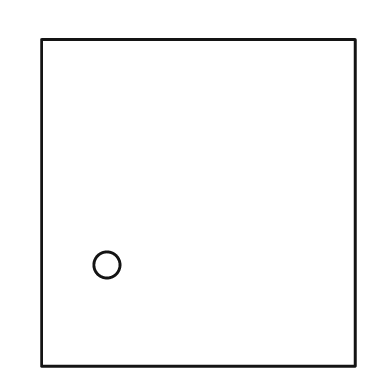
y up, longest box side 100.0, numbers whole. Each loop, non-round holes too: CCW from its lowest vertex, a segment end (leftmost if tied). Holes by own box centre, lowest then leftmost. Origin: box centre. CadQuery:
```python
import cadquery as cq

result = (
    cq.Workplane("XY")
    .moveTo(-48.0, -50.0)
    .lineTo(48.0, -50.0)
    .lineTo(48.0, 50.0)
    .lineTo(-48.0, 50.0)
    .close()
    .moveTo(-28.0, -19.0)
    .circle(4.0)
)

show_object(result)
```